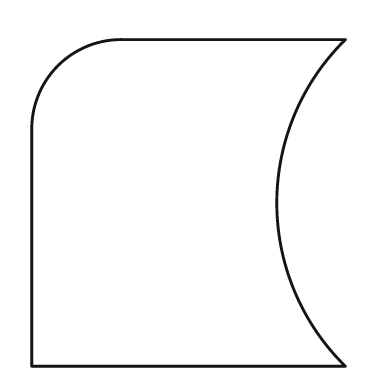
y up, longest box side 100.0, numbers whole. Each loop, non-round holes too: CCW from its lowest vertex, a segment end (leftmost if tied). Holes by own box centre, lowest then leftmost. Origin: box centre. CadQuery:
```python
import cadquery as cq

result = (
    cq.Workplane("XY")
    .moveTo(-48.0, -50.0)
    .lineTo(48.0, -50.0)
    .threePointArc((27.0, 0.0), (48.0, 50.0))
    .lineTo(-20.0, 50.0)
    .threePointArc((-40.0, 42.0), (-48.0, 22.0))
    .close()
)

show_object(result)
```